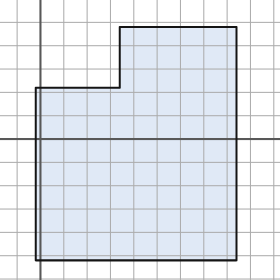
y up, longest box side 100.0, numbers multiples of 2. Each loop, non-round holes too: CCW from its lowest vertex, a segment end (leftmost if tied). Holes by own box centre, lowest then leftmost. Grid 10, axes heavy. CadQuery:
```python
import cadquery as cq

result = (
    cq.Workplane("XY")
    .moveTo(-2.0, -52.0)
    .lineTo(84.0, -52.0)
    .lineTo(84.0, 48.0)
    .lineTo(34.0, 48.0)
    .lineTo(34.0, 22.0)
    .lineTo(-2.0, 22.0)
    .close()
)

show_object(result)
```